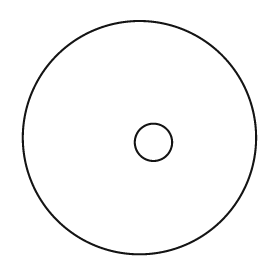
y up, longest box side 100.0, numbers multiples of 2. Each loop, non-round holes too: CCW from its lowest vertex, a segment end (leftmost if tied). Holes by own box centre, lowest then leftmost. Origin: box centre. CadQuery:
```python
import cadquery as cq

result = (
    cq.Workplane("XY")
    .moveTo(0.0, 0.0)
    .circle(50.0)
    .moveTo(6.0, -2.0)
    .circle(8.0)
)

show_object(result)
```